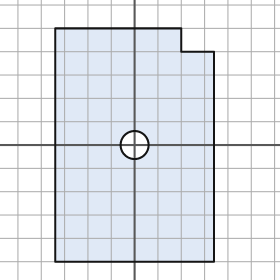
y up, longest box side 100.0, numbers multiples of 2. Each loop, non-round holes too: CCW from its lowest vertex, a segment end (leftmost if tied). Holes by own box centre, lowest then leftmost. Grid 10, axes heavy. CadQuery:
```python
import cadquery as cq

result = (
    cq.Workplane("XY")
    .moveTo(-34.0, -50.0)
    .lineTo(34.0, -50.0)
    .lineTo(34.0, 40.0)
    .lineTo(20.0, 40.0)
    .lineTo(20.0, 50.0)
    .lineTo(-34.0, 50.0)
    .close()
    .moveTo(0.0, 0.0)
    .circle(6.0)
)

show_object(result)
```